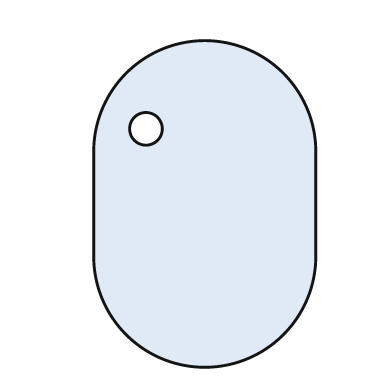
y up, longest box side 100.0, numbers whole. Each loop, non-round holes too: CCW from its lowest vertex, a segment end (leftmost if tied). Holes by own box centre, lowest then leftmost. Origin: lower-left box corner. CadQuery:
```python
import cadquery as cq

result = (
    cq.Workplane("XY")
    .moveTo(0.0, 34.0)
    .threePointArc((34.0, 0.0), (68.0, 34.0))
    .lineTo(68.0, 66.0)
    .threePointArc((34.0, 100.0), (0.0, 66.0))
    .close()
    .moveTo(16.0, 73.0)
    .circle(5.0)
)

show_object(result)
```